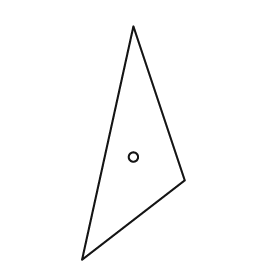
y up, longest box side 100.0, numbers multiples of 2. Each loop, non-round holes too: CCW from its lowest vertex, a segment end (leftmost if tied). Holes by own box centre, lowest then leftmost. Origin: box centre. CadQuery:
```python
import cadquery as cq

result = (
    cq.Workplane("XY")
    .moveTo(-22.0, -50.0)
    .lineTo(22.0, -16.0)
    .lineTo(0.0, 50.0)
    .close()
    .moveTo(0.0, -6.0)
    .circle(2.0)
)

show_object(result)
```